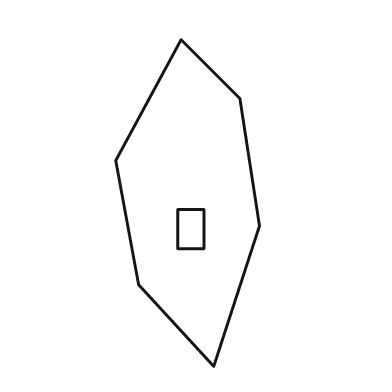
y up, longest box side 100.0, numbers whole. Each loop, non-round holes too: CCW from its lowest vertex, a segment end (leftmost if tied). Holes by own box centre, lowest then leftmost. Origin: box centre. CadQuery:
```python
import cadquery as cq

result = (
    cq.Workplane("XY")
    .moveTo(8.0, -50.0)
    .lineTo(22.0, -7.0)
    .lineTo(16.0, 32.0)
    .lineTo(-2.0, 50.0)
    .lineTo(-22.0, 13.0)
    .lineTo(-15.0, -25.0)
    .close()
    .moveTo(-3.0, -14.0)
    .lineTo(5.0, -14.0)
    .lineTo(5.0, -2.0)
    .lineTo(-3.0, -2.0)
    .close()
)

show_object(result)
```